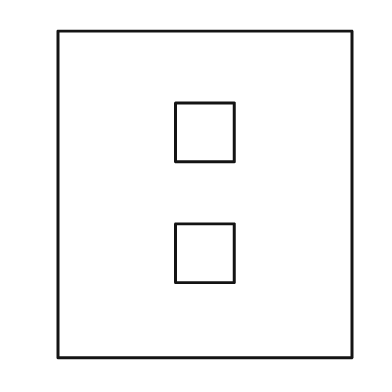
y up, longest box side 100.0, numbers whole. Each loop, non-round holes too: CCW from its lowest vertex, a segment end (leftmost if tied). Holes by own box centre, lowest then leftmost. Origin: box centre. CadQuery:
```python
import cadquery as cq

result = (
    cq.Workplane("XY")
    .moveTo(-45.0, -50.0)
    .lineTo(45.0, -50.0)
    .lineTo(45.0, 50.0)
    .lineTo(-45.0, 50.0)
    .close()
    .moveTo(-9.0, -27.0)
    .lineTo(9.0, -27.0)
    .lineTo(9.0, -9.0)
    .lineTo(-9.0, -9.0)
    .close()
    .moveTo(-9.0, 10.0)
    .lineTo(9.0, 10.0)
    .lineTo(9.0, 28.0)
    .lineTo(-9.0, 28.0)
    .close()
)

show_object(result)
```